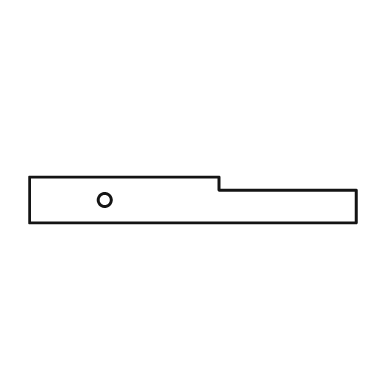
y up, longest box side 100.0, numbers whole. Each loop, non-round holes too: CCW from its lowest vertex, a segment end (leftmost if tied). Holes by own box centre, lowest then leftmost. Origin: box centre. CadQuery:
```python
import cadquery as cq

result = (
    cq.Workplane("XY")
    .moveTo(-50.0, -7.0)
    .lineTo(50.0, -7.0)
    .lineTo(50.0, 3.0)
    .lineTo(8.0, 3.0)
    .lineTo(8.0, 7.0)
    .lineTo(-50.0, 7.0)
    .close()
    .moveTo(-27.0, 0.0)
    .circle(2.0)
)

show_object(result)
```